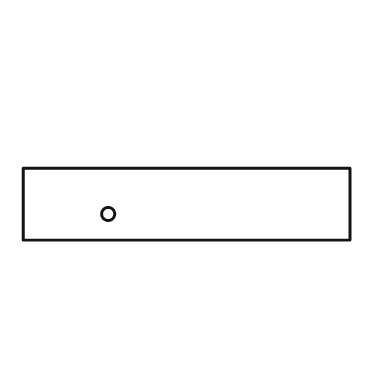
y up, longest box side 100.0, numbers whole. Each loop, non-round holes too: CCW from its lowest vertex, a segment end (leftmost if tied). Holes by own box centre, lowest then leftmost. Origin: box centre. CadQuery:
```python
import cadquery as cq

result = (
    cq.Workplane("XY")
    .moveTo(-50.0, -11.0)
    .lineTo(50.0, -11.0)
    .lineTo(50.0, 11.0)
    .lineTo(-50.0, 11.0)
    .close()
    .moveTo(-24.0, -3.0)
    .circle(2.0)
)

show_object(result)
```